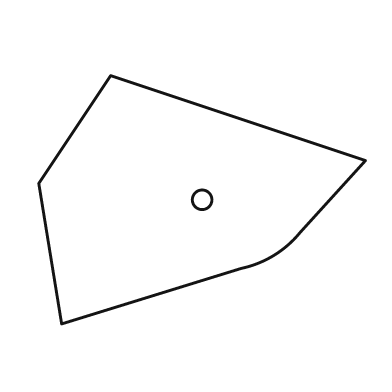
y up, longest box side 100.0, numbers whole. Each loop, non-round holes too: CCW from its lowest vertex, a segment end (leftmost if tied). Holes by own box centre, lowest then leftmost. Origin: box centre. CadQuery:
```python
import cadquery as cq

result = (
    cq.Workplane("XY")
    .moveTo(-43.0, -38.0)
    .lineTo(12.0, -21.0)
    .threePointArc((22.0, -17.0), (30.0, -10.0))
    .lineTo(50.0, 12.0)
    .lineTo(-28.0, 38.0)
    .lineTo(-50.0, 5.0)
    .close()
    .moveTo(0.0, 0.0)
    .circle(3.0)
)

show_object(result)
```